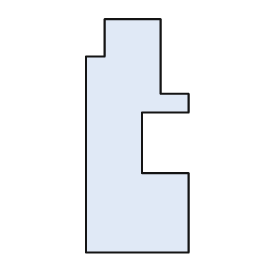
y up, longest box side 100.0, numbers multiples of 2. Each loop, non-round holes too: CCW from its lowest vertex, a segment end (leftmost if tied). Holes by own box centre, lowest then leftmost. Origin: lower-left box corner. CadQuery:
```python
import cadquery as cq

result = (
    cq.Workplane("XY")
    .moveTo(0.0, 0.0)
    .lineTo(44.0, 0.0)
    .lineTo(44.0, 34.0)
    .lineTo(24.0, 34.0)
    .lineTo(24.0, 60.0)
    .lineTo(44.0, 60.0)
    .lineTo(44.0, 68.0)
    .lineTo(32.0, 68.0)
    .lineTo(32.0, 100.0)
    .lineTo(8.0, 100.0)
    .lineTo(8.0, 84.0)
    .lineTo(0.0, 84.0)
    .close()
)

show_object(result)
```